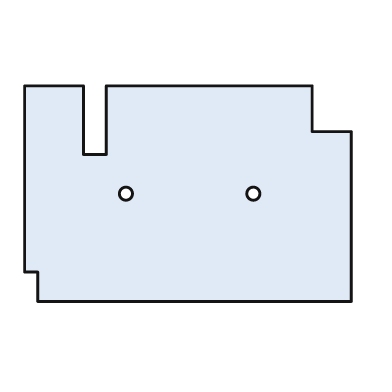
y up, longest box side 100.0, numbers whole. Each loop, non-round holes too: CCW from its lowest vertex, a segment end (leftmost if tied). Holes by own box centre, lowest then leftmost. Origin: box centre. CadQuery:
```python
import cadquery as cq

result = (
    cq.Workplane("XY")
    .moveTo(-46.0, -33.0)
    .lineTo(50.0, -33.0)
    .lineTo(50.0, 19.0)
    .lineTo(38.0, 19.0)
    .lineTo(38.0, 33.0)
    .lineTo(-25.0, 33.0)
    .lineTo(-25.0, 12.0)
    .lineTo(-32.0, 12.0)
    .lineTo(-32.0, 33.0)
    .lineTo(-50.0, 33.0)
    .lineTo(-50.0, -24.0)
    .lineTo(-46.0, -24.0)
    .close()
    .moveTo(-19.0, 0.0)
    .circle(2.0)
    .moveTo(20.0, 0.0)
    .circle(2.0)
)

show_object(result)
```